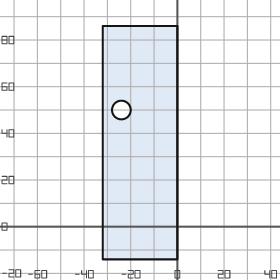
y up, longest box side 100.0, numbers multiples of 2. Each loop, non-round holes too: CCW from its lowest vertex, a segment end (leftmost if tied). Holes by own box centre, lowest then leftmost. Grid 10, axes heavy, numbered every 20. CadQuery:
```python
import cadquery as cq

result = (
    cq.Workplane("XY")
    .moveTo(-32.0, -14.0)
    .lineTo(0.0, -14.0)
    .lineTo(0.0, 86.0)
    .lineTo(-32.0, 86.0)
    .close()
    .moveTo(-24.0, 50.0)
    .circle(4.0)
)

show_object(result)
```